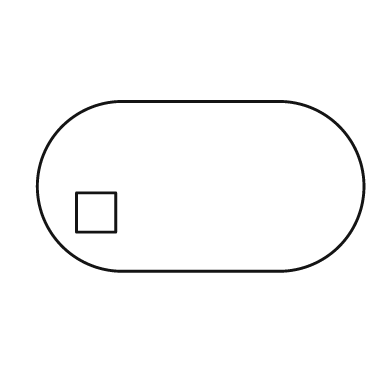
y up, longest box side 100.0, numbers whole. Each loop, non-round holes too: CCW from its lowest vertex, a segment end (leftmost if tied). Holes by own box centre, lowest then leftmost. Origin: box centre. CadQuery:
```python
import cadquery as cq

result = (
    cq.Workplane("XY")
    .moveTo(-24.0, -26.0)
    .lineTo(24.0, -26.0)
    .threePointArc((50.0, 0.0), (24.0, 26.0))
    .lineTo(-24.0, 26.0)
    .threePointArc((-50.0, 0.0), (-24.0, -26.0))
    .close()
    .moveTo(-38.0, -14.0)
    .lineTo(-26.0, -14.0)
    .lineTo(-26.0, -2.0)
    .lineTo(-38.0, -2.0)
    .close()
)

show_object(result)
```